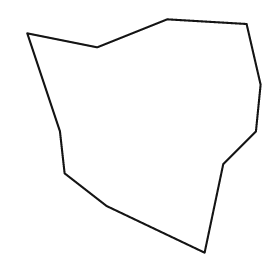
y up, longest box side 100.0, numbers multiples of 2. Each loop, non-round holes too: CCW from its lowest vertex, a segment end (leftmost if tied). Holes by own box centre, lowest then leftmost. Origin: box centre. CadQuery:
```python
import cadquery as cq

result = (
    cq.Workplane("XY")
    .moveTo(26.0, -50.0)
    .lineTo(34.0, -12.0)
    .lineTo(48.0, 2.0)
    .lineTo(50.0, 22.0)
    .lineTo(44.0, 48.0)
    .lineTo(10.0, 50.0)
    .lineTo(-20.0, 38.0)
    .lineTo(-50.0, 44.0)
    .lineTo(-36.0, 2.0)
    .lineTo(-34.0, -16.0)
    .lineTo(-16.0, -30.0)
    .close()
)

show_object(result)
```